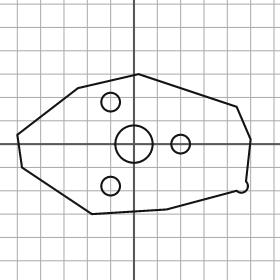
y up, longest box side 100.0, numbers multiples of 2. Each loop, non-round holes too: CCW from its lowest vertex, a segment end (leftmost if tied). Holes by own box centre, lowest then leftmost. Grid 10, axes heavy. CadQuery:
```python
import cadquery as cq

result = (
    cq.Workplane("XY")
    .moveTo(-18.0, -30.0)
    .lineTo(14.0, -28.0)
    .lineTo(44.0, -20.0)
    .threePointArc((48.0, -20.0), (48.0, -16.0))
    .lineTo(50.0, 2.0)
    .lineTo(44.0, 16.0)
    .lineTo(2.0, 30.0)
    .lineTo(-24.0, 24.0)
    .lineTo(-50.0, 4.0)
    .lineTo(-48.0, -10.0)
    .close()
    .moveTo(-10.0, -18.0)
    .circle(4.0)
    .moveTo(0.0, 0.0)
    .circle(8.0)
    .moveTo(20.0, 0.0)
    .circle(4.0)
    .moveTo(-10.0, 18.0)
    .circle(4.0)
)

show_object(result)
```